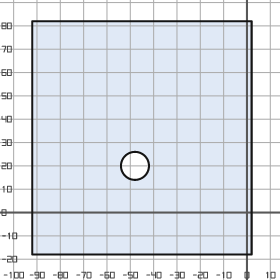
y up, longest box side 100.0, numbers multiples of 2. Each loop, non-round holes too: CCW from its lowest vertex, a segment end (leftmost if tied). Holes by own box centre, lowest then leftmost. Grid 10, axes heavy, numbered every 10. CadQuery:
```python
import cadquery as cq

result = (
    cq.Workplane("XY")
    .moveTo(-92.0, -18.0)
    .lineTo(2.0, -18.0)
    .lineTo(2.0, 82.0)
    .lineTo(-92.0, 82.0)
    .close()
    .moveTo(-48.0, 20.0)
    .circle(6.0)
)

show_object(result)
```